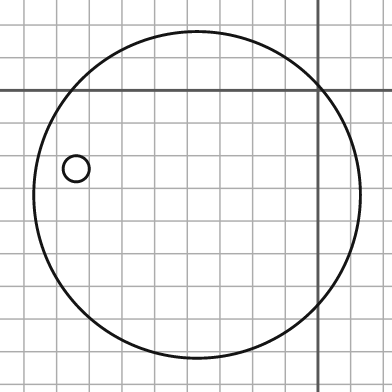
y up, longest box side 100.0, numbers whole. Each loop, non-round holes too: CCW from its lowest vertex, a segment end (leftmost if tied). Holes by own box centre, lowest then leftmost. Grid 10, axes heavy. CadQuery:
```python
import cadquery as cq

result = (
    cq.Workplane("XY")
    .moveTo(-37.0, -32.0)
    .circle(50.0)
    .moveTo(-74.0, -24.0)
    .circle(4.0)
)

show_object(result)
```